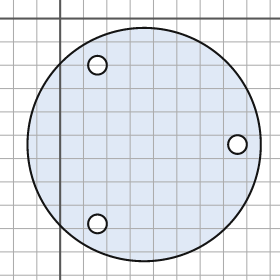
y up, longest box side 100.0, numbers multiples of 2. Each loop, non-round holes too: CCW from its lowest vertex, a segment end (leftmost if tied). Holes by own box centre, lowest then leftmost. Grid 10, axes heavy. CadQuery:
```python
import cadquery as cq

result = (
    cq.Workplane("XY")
    .moveTo(36.0, -54.0)
    .circle(50.0)
    .moveTo(16.0, -88.0)
    .circle(4.0)
    .moveTo(76.0, -54.0)
    .circle(4.0)
    .moveTo(16.0, -20.0)
    .circle(4.0)
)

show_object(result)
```